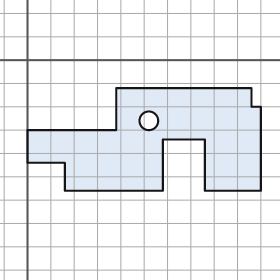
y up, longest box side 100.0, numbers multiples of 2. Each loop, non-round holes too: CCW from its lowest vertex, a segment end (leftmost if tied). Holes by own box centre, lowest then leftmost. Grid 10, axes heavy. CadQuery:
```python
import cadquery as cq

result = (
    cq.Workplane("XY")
    .moveTo(16.0, -56.0)
    .lineTo(58.0, -56.0)
    .lineTo(58.0, -34.0)
    .lineTo(76.0, -34.0)
    .lineTo(76.0, -56.0)
    .lineTo(100.0, -56.0)
    .lineTo(100.0, -20.0)
    .lineTo(96.0, -20.0)
    .lineTo(96.0, -12.0)
    .lineTo(38.0, -12.0)
    .lineTo(38.0, -30.0)
    .lineTo(0.0, -30.0)
    .lineTo(0.0, -44.0)
    .lineTo(16.0, -44.0)
    .close()
    .moveTo(52.0, -26.0)
    .circle(4.0)
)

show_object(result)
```